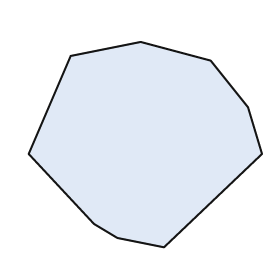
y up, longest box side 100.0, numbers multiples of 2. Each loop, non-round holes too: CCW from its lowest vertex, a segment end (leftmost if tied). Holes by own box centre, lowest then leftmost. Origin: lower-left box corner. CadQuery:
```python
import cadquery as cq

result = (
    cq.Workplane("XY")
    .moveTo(58.0, 0.0)
    .lineTo(100.0, 40.0)
    .lineTo(94.0, 60.0)
    .lineTo(78.0, 80.0)
    .lineTo(48.0, 88.0)
    .lineTo(18.0, 82.0)
    .lineTo(0.0, 40.0)
    .lineTo(28.0, 10.0)
    .lineTo(38.0, 4.0)
    .close()
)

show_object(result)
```